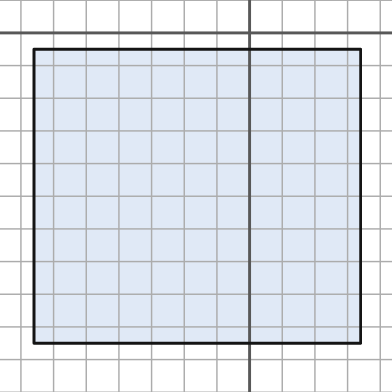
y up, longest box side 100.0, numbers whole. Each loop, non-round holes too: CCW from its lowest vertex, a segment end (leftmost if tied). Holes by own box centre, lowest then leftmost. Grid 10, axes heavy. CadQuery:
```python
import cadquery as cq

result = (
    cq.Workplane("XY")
    .moveTo(-66.0, -95.0)
    .lineTo(34.0, -95.0)
    .lineTo(34.0, -5.0)
    .lineTo(-66.0, -5.0)
    .close()
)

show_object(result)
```